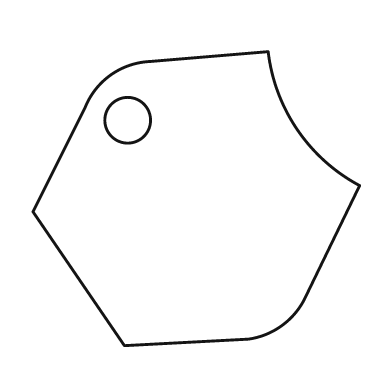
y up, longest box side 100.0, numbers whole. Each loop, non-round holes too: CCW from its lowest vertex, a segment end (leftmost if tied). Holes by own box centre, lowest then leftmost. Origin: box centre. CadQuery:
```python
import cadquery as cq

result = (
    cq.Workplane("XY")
    .moveTo(-22.0, -45.0)
    .lineTo(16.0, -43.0)
    .threePointArc((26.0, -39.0), (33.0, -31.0))
    .lineTo(50.0, 4.0)
    .threePointArc((31.0, 21.0), (22.0, 45.0))
    .lineTo(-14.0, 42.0)
    .threePointArc((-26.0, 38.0), (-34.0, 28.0))
    .lineTo(-50.0, -4.0)
    .close()
    .moveTo(-21.0, 24.0)
    .circle(7.0)
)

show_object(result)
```